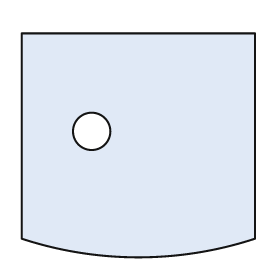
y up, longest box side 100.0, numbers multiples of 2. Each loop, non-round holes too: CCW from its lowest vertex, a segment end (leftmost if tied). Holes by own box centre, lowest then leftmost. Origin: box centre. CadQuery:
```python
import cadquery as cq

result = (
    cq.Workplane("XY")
    .moveTo(-50.0, -40.0)
    .threePointArc((0.0, -48.0), (50.0, -40.0))
    .lineTo(50.0, 48.0)
    .lineTo(-50.0, 48.0)
    .close()
    .moveTo(-20.0, 6.0)
    .circle(8.0)
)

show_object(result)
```